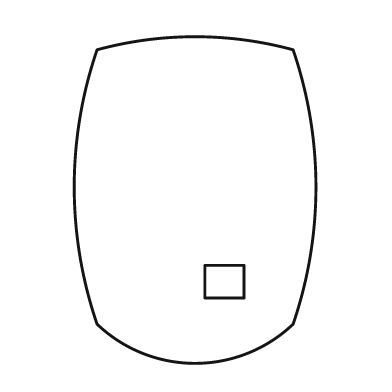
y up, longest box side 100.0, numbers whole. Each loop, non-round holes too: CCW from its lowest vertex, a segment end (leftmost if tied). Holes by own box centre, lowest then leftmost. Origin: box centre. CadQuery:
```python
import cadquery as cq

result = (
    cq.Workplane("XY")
    .moveTo(-30.0, -38.0)
    .threePointArc((0.0, -50.0), (30.0, -38.0))
    .threePointArc((37.0, 4.0), (30.0, 46.0))
    .threePointArc((0.0, 50.0), (-30.0, 46.0))
    .threePointArc((-37.0, 4.0), (-30.0, -38.0))
    .close()
    .moveTo(3.0, -30.0)
    .lineTo(15.0, -30.0)
    .lineTo(15.0, -20.0)
    .lineTo(3.0, -20.0)
    .close()
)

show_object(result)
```